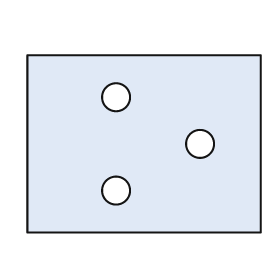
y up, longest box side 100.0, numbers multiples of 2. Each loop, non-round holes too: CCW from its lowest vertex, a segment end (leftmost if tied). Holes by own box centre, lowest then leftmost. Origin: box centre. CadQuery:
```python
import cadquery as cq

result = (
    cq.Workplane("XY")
    .moveTo(-50.0, -38.0)
    .lineTo(50.0, -38.0)
    .lineTo(50.0, 38.0)
    .lineTo(-50.0, 38.0)
    .close()
    .moveTo(-12.0, -20.0)
    .circle(6.0)
    .moveTo(24.0, 0.0)
    .circle(6.0)
    .moveTo(-12.0, 20.0)
    .circle(6.0)
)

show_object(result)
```